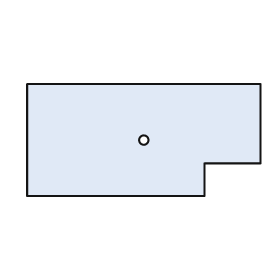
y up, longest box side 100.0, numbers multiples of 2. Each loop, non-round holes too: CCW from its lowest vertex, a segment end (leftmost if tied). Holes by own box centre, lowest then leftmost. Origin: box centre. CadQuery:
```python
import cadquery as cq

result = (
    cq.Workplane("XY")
    .moveTo(-50.0, -24.0)
    .lineTo(26.0, -24.0)
    .lineTo(26.0, -10.0)
    .lineTo(50.0, -10.0)
    .lineTo(50.0, 24.0)
    .lineTo(-50.0, 24.0)
    .close()
    .moveTo(0.0, 0.0)
    .circle(2.0)
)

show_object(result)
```